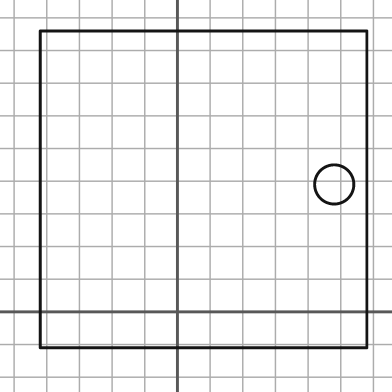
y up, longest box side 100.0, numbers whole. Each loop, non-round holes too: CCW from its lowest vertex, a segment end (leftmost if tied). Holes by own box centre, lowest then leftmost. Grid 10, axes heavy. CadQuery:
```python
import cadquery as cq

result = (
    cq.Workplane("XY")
    .moveTo(-42.0, -11.0)
    .lineTo(58.0, -11.0)
    .lineTo(58.0, 86.0)
    .lineTo(-42.0, 86.0)
    .close()
    .moveTo(48.0, 39.0)
    .circle(6.0)
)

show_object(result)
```